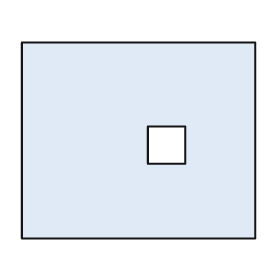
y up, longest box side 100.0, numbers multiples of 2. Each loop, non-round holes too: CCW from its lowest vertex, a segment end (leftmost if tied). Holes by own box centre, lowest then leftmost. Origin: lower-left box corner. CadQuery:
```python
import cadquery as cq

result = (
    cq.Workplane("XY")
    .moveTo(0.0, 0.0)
    .lineTo(100.0, 0.0)
    .lineTo(100.0, 84.0)
    .lineTo(0.0, 84.0)
    .close()
    .moveTo(54.0, 32.0)
    .lineTo(70.0, 32.0)
    .lineTo(70.0, 48.0)
    .lineTo(54.0, 48.0)
    .close()
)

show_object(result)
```